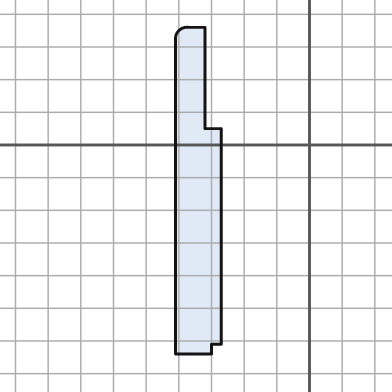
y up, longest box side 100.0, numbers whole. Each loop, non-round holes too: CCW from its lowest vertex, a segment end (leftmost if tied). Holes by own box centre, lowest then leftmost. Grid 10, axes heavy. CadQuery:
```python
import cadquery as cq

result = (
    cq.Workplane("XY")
    .moveTo(-41.0, -64.0)
    .lineTo(-30.0, -64.0)
    .lineTo(-30.0, -61.0)
    .lineTo(-27.0, -61.0)
    .lineTo(-27.0, 5.0)
    .lineTo(-32.0, 5.0)
    .lineTo(-32.0, 36.0)
    .lineTo(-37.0, 36.0)
    .threePointArc((-40.0, 35.0), (-41.0, 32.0))
    .close()
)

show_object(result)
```